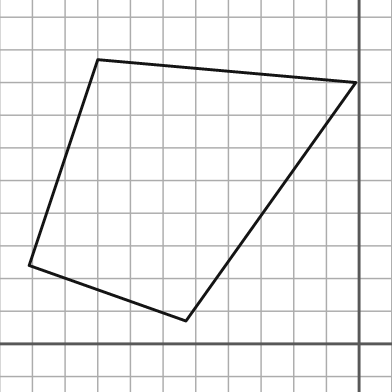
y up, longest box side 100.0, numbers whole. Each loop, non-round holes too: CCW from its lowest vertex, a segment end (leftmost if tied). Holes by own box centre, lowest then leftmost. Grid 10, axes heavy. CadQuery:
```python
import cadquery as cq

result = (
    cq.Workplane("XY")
    .moveTo(-53.0, 7.0)
    .lineTo(-1.0, 80.0)
    .lineTo(-80.0, 87.0)
    .lineTo(-101.0, 24.0)
    .close()
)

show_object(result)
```